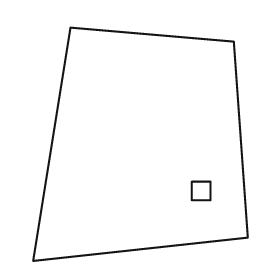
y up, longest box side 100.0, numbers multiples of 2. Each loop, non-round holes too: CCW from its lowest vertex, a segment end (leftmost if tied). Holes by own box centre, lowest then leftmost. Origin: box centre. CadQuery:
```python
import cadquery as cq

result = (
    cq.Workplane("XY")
    .moveTo(-46.0, -50.0)
    .lineTo(46.0, -40.0)
    .lineTo(40.0, 44.0)
    .lineTo(-30.0, 50.0)
    .close()
    .moveTo(22.0, -24.0)
    .lineTo(30.0, -24.0)
    .lineTo(30.0, -16.0)
    .lineTo(22.0, -16.0)
    .close()
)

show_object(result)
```